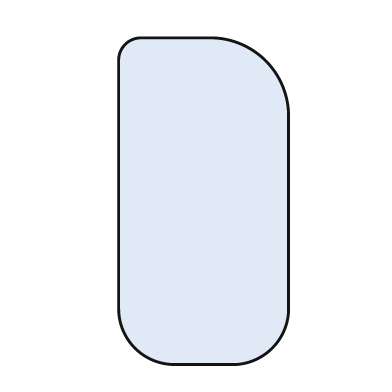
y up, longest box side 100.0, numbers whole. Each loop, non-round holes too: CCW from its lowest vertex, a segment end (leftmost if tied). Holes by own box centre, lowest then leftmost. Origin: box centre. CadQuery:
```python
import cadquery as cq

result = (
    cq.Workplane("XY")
    .moveTo(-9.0, -50.0)
    .lineTo(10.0, -50.0)
    .threePointArc((21.0, -45.0), (26.0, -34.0))
    .lineTo(26.0, 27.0)
    .threePointArc((19.0, 43.0), (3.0, 50.0))
    .lineTo(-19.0, 50.0)
    .threePointArc((-24.0, 48.0), (-26.0, 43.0))
    .lineTo(-26.0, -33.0)
    .threePointArc((-21.0, -45.0), (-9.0, -50.0))
    .close()
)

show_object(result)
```